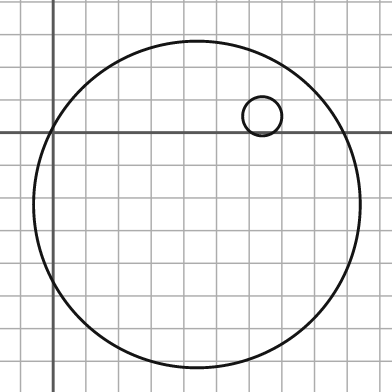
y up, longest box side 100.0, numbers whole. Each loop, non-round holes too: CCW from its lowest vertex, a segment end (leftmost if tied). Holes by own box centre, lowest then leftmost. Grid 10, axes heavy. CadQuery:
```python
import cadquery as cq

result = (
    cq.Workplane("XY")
    .moveTo(44.0, -22.0)
    .circle(50.0)
    .moveTo(64.0, 5.0)
    .circle(6.0)
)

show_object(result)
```